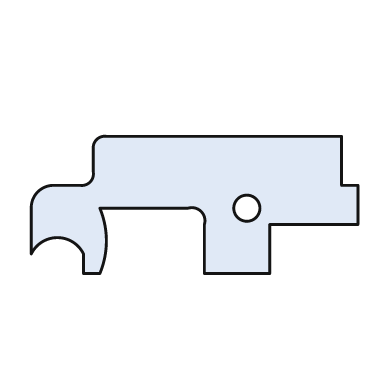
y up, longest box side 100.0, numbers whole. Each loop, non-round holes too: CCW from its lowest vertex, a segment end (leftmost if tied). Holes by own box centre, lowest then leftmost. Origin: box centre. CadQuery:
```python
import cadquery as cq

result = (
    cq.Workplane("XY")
    .moveTo(-34.0, -21.0)
    .lineTo(-29.0, -21.0)
    .threePointArc((-27.0, -11.0), (-29.0, -1.0))
    .lineTo(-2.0, -1.0)
    .threePointArc((2.0, -2.0), (3.0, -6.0))
    .lineTo(3.0, -21.0)
    .lineTo(23.0, -21.0)
    .lineTo(23.0, -6.0)
    .lineTo(50.0, -6.0)
    .lineTo(50.0, 6.0)
    .lineTo(45.0, 6.0)
    .lineTo(45.0, 21.0)
    .lineTo(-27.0, 21.0)
    .threePointArc((-30.0, 20.0), (-31.0, 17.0))
    .lineTo(-31.0, 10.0)
    .threePointArc((-32.0, 7.0), (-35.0, 6.0))
    .lineTo(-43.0, 6.0)
    .threePointArc((-48.0, 4.0), (-50.0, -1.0))
    .lineTo(-50.0, -15.0)
    .threePointArc((-42.0, -10.0), (-34.0, -15.0))
    .close()
    .moveTo(16.0, -1.0)
    .circle(4.0)
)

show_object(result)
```